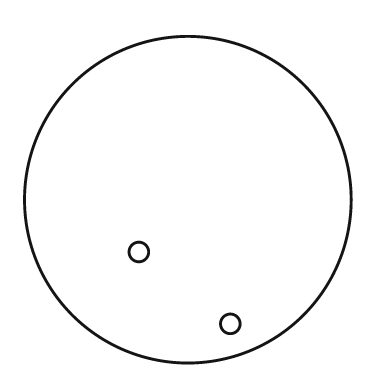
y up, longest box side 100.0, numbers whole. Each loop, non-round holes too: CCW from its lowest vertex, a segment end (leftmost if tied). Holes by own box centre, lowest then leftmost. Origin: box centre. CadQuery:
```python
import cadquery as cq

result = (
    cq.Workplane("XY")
    .moveTo(0.0, 0.0)
    .circle(50.0)
    .moveTo(13.0, -38.0)
    .circle(3.0)
    .moveTo(-15.0, -16.0)
    .circle(3.0)
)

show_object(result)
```